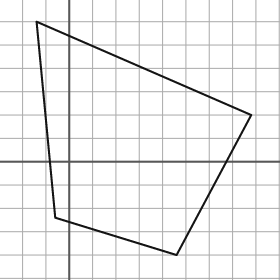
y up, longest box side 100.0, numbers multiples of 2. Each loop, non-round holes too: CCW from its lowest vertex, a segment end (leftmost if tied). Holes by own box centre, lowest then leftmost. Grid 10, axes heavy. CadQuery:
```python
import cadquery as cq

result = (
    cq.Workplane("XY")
    .moveTo(46.0, -40.0)
    .lineTo(78.0, 20.0)
    .lineTo(-14.0, 60.0)
    .lineTo(-6.0, -24.0)
    .close()
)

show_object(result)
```